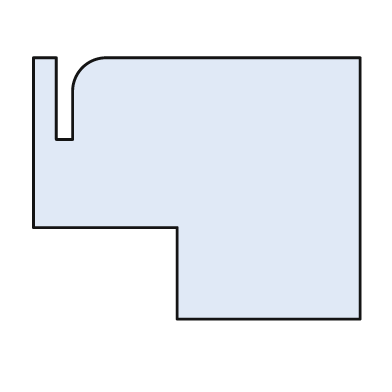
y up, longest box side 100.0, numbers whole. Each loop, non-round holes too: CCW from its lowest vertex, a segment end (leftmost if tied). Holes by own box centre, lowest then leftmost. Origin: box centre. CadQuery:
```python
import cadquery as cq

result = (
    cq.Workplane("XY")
    .moveTo(-6.0, -40.0)
    .lineTo(50.0, -40.0)
    .lineTo(50.0, 40.0)
    .lineTo(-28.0, 40.0)
    .threePointArc((-35.0, 37.0), (-38.0, 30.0))
    .lineTo(-38.0, 15.0)
    .lineTo(-43.0, 15.0)
    .lineTo(-43.0, 40.0)
    .lineTo(-50.0, 40.0)
    .lineTo(-50.0, -12.0)
    .lineTo(-6.0, -12.0)
    .close()
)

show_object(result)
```